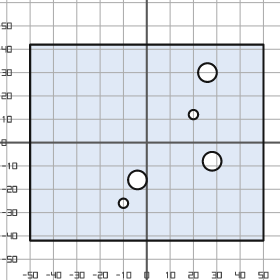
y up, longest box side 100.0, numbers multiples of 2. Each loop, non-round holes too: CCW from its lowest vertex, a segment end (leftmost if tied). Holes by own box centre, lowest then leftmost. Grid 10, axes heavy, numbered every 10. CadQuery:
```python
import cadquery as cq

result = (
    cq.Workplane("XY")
    .moveTo(-50.0, -42.0)
    .lineTo(50.0, -42.0)
    .lineTo(50.0, 42.0)
    .lineTo(-50.0, 42.0)
    .close()
    .moveTo(-10.0, -26.0)
    .circle(2.0)
    .moveTo(-4.0, -16.0)
    .circle(4.0)
    .moveTo(28.0, -8.0)
    .circle(4.0)
    .moveTo(20.0, 12.0)
    .circle(2.0)
    .moveTo(26.0, 30.0)
    .circle(4.0)
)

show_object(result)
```